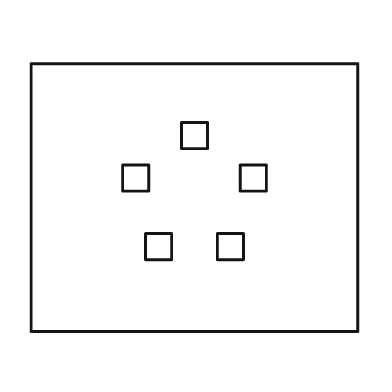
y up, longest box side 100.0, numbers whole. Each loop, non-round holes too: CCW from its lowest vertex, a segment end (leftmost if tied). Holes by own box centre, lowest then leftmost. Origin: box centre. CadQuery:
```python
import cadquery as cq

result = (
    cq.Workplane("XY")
    .moveTo(-50.0, -41.0)
    .lineTo(50.0, -41.0)
    .lineTo(50.0, 41.0)
    .lineTo(-50.0, 41.0)
    .close()
    .moveTo(-15.0, -19.0)
    .lineTo(-7.0, -19.0)
    .lineTo(-7.0, -11.0)
    .lineTo(-15.0, -11.0)
    .close()
    .moveTo(7.0, -19.0)
    .lineTo(15.0, -19.0)
    .lineTo(15.0, -11.0)
    .lineTo(7.0, -11.0)
    .close()
    .moveTo(-22.0, 2.0)
    .lineTo(-14.0, 2.0)
    .lineTo(-14.0, 10.0)
    .lineTo(-22.0, 10.0)
    .close()
    .moveTo(14.0, 2.0)
    .lineTo(22.0, 2.0)
    .lineTo(22.0, 10.0)
    .lineTo(14.0, 10.0)
    .close()
    .moveTo(-4.0, 15.0)
    .lineTo(4.0, 15.0)
    .lineTo(4.0, 23.0)
    .lineTo(-4.0, 23.0)
    .close()
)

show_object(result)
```